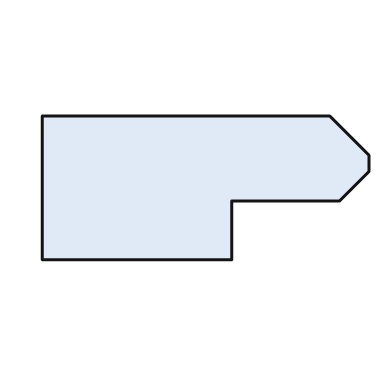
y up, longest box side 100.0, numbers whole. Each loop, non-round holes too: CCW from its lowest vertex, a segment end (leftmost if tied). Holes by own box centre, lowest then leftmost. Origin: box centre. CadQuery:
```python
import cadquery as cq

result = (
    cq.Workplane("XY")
    .moveTo(-50.0, -22.0)
    .lineTo(8.0, -22.0)
    .lineTo(8.0, -4.0)
    .lineTo(41.0, -4.0)
    .lineTo(50.0, 5.0)
    .lineTo(50.0, 10.0)
    .lineTo(38.0, 22.0)
    .lineTo(-50.0, 22.0)
    .close()
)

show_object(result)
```